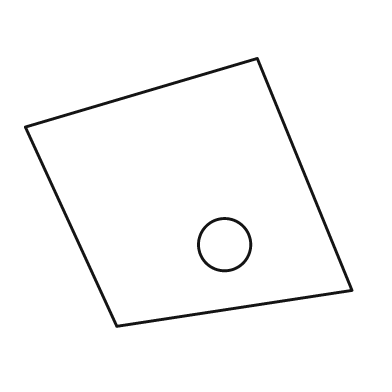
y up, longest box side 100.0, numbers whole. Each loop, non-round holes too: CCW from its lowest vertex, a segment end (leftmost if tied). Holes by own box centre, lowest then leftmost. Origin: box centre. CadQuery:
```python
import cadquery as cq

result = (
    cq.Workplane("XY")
    .moveTo(-22.0, -41.0)
    .lineTo(50.0, -30.0)
    .lineTo(21.0, 41.0)
    .lineTo(-50.0, 20.0)
    .close()
    .moveTo(11.0, -16.0)
    .circle(8.0)
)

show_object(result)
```